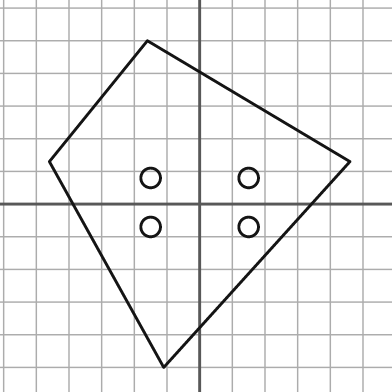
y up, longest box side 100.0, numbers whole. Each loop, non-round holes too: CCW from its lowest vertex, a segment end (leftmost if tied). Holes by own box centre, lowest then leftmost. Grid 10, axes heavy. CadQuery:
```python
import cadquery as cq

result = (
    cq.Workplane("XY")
    .moveTo(-11.0, -50.0)
    .lineTo(46.0, 13.0)
    .lineTo(-16.0, 50.0)
    .lineTo(-46.0, 13.0)
    .close()
    .moveTo(-15.0, -7.0)
    .circle(3.0)
    .moveTo(15.0, -7.0)
    .circle(3.0)
    .moveTo(-15.0, 8.0)
    .circle(3.0)
    .moveTo(15.0, 8.0)
    .circle(3.0)
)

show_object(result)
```